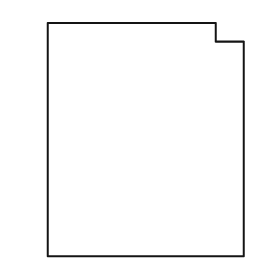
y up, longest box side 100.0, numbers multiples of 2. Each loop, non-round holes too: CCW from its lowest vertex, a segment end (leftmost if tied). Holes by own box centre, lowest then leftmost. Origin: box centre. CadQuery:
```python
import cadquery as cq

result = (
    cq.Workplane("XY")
    .moveTo(-42.0, -50.0)
    .lineTo(42.0, -50.0)
    .lineTo(42.0, 42.0)
    .lineTo(30.0, 42.0)
    .lineTo(30.0, 50.0)
    .lineTo(-42.0, 50.0)
    .close()
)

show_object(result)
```